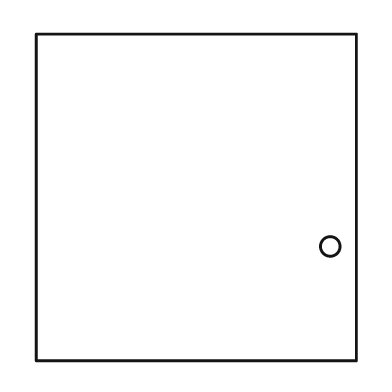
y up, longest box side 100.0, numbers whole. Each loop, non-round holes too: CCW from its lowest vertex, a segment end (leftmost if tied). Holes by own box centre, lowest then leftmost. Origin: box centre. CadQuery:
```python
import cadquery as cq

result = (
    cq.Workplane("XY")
    .moveTo(-49.0, -50.0)
    .lineTo(49.0, -50.0)
    .lineTo(49.0, 50.0)
    .lineTo(-49.0, 50.0)
    .close()
    .moveTo(41.0, -15.0)
    .circle(3.0)
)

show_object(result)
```